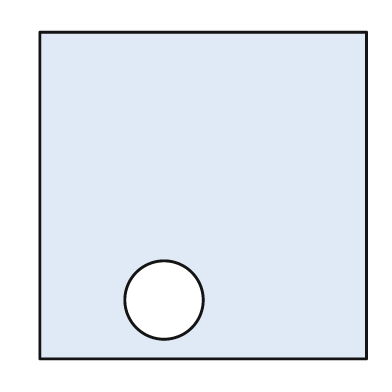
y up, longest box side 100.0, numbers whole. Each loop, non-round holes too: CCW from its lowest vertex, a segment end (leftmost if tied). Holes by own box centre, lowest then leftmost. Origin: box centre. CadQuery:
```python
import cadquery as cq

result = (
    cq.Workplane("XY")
    .moveTo(-50.0, -50.0)
    .lineTo(50.0, -50.0)
    .lineTo(50.0, 50.0)
    .lineTo(-50.0, 50.0)
    .close()
    .moveTo(-12.0, -32.0)
    .circle(12.0)
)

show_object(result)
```